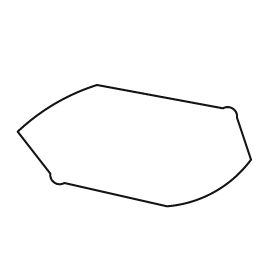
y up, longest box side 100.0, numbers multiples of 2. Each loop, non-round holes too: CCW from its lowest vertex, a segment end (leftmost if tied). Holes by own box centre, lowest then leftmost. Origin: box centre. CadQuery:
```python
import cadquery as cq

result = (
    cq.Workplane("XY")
    .moveTo(14.0, -26.0)
    .threePointArc((34.0, -20.0), (50.0, -6.0))
    .lineTo(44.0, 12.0)
    .threePointArc((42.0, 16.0), (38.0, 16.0))
    .lineTo(-16.0, 26.0)
    .threePointArc((-34.0, 18.0), (-50.0, 6.0))
    .lineTo(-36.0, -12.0)
    .threePointArc((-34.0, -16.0), (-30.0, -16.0))
    .close()
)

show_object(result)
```